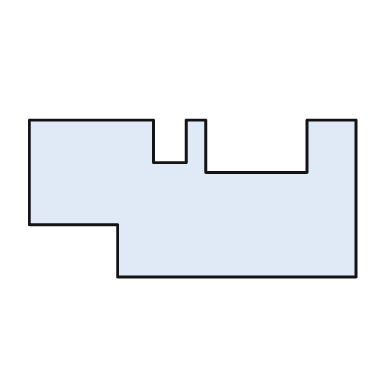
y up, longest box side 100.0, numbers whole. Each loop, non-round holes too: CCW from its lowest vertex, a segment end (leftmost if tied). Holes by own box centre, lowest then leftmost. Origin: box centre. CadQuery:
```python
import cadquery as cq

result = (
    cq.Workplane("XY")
    .moveTo(-23.0, -24.0)
    .lineTo(50.0, -24.0)
    .lineTo(50.0, 24.0)
    .lineTo(35.0, 24.0)
    .lineTo(35.0, 8.0)
    .lineTo(4.0, 8.0)
    .lineTo(4.0, 24.0)
    .lineTo(-2.0, 24.0)
    .lineTo(-2.0, 11.0)
    .lineTo(-12.0, 11.0)
    .lineTo(-12.0, 24.0)
    .lineTo(-50.0, 24.0)
    .lineTo(-50.0, -8.0)
    .lineTo(-23.0, -8.0)
    .close()
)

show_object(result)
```